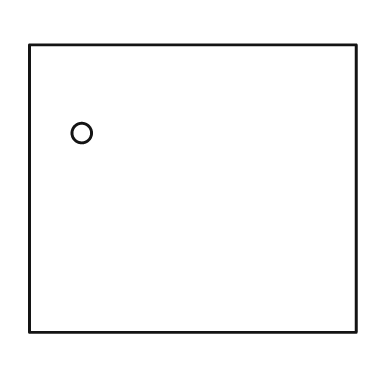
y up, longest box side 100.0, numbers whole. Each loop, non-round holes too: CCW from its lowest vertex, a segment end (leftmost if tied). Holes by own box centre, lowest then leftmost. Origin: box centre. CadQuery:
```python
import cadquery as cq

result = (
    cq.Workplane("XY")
    .moveTo(-50.0, -44.0)
    .lineTo(50.0, -44.0)
    .lineTo(50.0, 44.0)
    .lineTo(-50.0, 44.0)
    .close()
    .moveTo(-34.0, 17.0)
    .circle(3.0)
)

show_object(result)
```